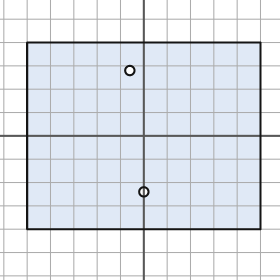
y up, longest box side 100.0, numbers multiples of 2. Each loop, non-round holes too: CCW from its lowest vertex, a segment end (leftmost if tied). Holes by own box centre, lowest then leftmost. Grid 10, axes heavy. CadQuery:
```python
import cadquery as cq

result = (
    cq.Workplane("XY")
    .moveTo(-50.0, -40.0)
    .lineTo(50.0, -40.0)
    .lineTo(50.0, 40.0)
    .lineTo(-50.0, 40.0)
    .close()
    .moveTo(0.0, -24.0)
    .circle(2.0)
    .moveTo(-6.0, 28.0)
    .circle(2.0)
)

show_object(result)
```